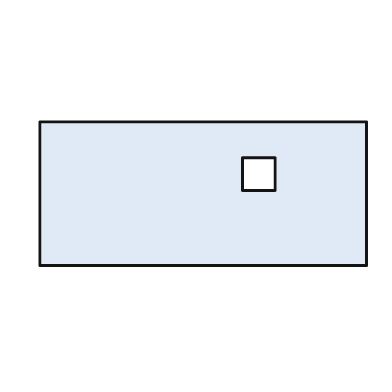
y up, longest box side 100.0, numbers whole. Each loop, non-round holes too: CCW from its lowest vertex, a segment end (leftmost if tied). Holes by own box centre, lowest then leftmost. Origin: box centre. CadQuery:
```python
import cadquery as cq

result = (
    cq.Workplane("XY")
    .moveTo(-50.0, -22.0)
    .lineTo(50.0, -22.0)
    .lineTo(50.0, 22.0)
    .lineTo(-50.0, 22.0)
    .close()
    .moveTo(12.0, 1.0)
    .lineTo(22.0, 1.0)
    .lineTo(22.0, 11.0)
    .lineTo(12.0, 11.0)
    .close()
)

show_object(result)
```